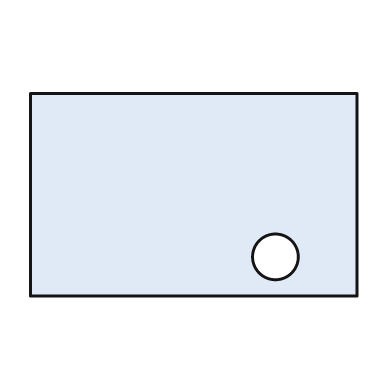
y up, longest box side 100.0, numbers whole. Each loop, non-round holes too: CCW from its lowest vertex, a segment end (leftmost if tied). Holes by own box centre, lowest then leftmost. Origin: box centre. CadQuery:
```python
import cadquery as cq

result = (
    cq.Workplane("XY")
    .moveTo(-50.0, -31.0)
    .lineTo(50.0, -31.0)
    .lineTo(50.0, 31.0)
    .lineTo(-50.0, 31.0)
    .close()
    .moveTo(25.0, -19.0)
    .circle(7.0)
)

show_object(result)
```